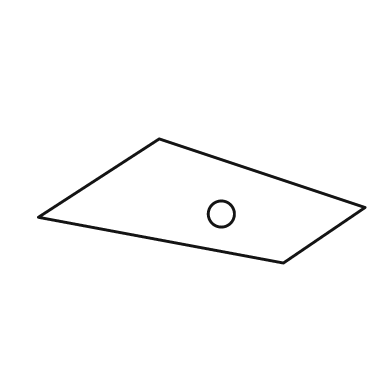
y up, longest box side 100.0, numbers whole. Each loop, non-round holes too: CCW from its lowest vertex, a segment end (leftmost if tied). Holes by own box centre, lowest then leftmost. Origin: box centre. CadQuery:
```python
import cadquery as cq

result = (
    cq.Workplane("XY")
    .moveTo(25.0, -19.0)
    .lineTo(50.0, -2.0)
    .lineTo(-13.0, 19.0)
    .lineTo(-50.0, -5.0)
    .close()
    .moveTo(6.0, -4.0)
    .circle(4.0)
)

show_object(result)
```